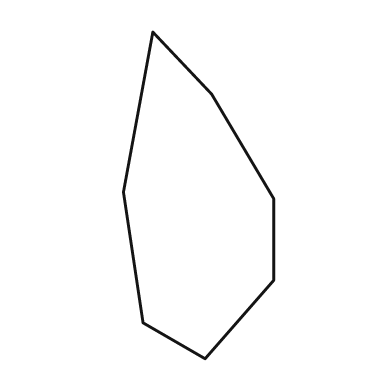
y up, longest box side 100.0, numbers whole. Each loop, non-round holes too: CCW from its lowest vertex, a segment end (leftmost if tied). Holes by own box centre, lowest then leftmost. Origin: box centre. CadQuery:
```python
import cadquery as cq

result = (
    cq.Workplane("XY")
    .moveTo(2.0, -50.0)
    .lineTo(23.0, -26.0)
    .lineTo(23.0, -1.0)
    .lineTo(4.0, 31.0)
    .lineTo(-14.0, 50.0)
    .lineTo(-23.0, 1.0)
    .lineTo(-17.0, -39.0)
    .close()
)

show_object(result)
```